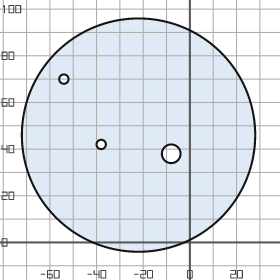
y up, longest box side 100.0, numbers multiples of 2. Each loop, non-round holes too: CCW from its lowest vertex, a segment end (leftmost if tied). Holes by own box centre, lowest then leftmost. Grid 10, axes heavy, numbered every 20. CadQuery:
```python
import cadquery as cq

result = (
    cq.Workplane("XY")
    .moveTo(-22.0, 46.0)
    .circle(50.0)
    .moveTo(-8.0, 38.0)
    .circle(4.0)
    .moveTo(-38.0, 42.0)
    .circle(2.0)
    .moveTo(-54.0, 70.0)
    .circle(2.0)
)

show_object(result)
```